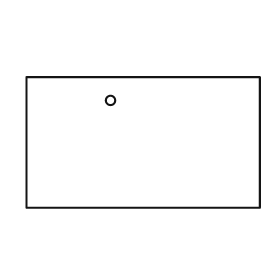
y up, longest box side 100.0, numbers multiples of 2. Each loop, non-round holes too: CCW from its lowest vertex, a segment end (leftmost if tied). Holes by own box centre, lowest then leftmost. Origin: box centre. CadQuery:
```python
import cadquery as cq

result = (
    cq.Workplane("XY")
    .moveTo(-50.0, -28.0)
    .lineTo(50.0, -28.0)
    .lineTo(50.0, 28.0)
    .lineTo(-50.0, 28.0)
    .close()
    .moveTo(-14.0, 18.0)
    .circle(2.0)
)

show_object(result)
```